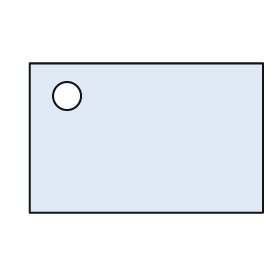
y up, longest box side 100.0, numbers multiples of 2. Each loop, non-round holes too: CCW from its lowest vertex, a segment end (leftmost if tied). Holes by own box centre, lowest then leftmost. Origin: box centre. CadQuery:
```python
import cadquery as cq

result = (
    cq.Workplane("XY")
    .moveTo(-50.0, -32.0)
    .lineTo(50.0, -32.0)
    .lineTo(50.0, 32.0)
    .lineTo(-50.0, 32.0)
    .close()
    .moveTo(-34.0, 18.0)
    .circle(6.0)
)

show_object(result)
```